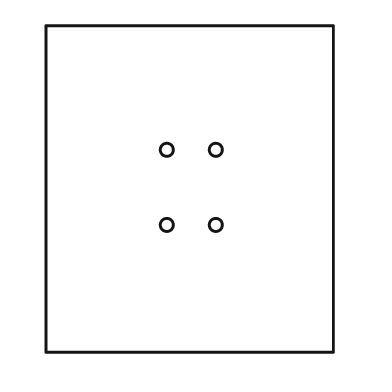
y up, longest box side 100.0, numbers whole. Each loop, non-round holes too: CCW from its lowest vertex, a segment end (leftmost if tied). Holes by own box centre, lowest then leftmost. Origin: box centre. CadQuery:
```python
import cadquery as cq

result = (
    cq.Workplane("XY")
    .moveTo(-44.0, -50.0)
    .lineTo(44.0, -50.0)
    .lineTo(44.0, 50.0)
    .lineTo(-44.0, 50.0)
    .close()
    .moveTo(-7.0, -11.0)
    .circle(2.0)
    .moveTo(8.0, -11.0)
    .circle(2.0)
    .moveTo(-7.0, 12.0)
    .circle(2.0)
    .moveTo(8.0, 12.0)
    .circle(2.0)
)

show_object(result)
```